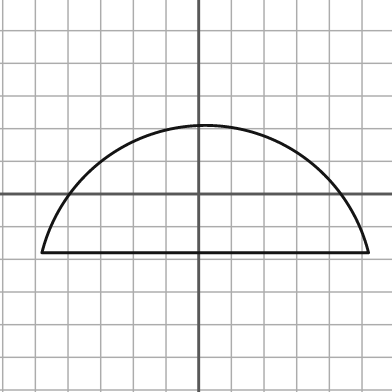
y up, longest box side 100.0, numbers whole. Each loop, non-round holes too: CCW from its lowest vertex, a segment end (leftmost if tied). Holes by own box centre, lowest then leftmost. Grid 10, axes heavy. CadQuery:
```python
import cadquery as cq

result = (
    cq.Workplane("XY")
    .moveTo(-48.0, -18.0)
    .lineTo(52.0, -18.0)
    .threePointArc((2.0, 21.0), (-48.0, -18.0))
    .close()
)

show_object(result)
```